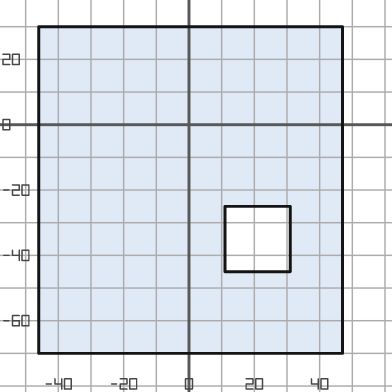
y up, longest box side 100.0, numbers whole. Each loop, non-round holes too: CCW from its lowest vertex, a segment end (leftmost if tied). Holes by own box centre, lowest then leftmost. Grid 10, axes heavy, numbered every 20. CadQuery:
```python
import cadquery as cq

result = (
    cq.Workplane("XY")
    .moveTo(-46.0, -70.0)
    .lineTo(47.0, -70.0)
    .lineTo(47.0, 30.0)
    .lineTo(-46.0, 30.0)
    .close()
    .moveTo(11.0, -45.0)
    .lineTo(31.0, -45.0)
    .lineTo(31.0, -25.0)
    .lineTo(11.0, -25.0)
    .close()
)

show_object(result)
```